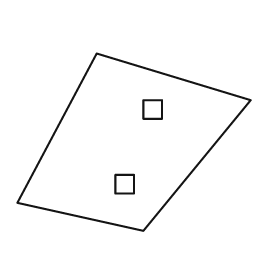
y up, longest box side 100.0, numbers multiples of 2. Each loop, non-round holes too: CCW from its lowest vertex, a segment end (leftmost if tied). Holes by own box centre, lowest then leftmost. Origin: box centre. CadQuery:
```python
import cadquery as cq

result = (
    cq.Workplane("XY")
    .moveTo(4.0, -38.0)
    .lineTo(50.0, 18.0)
    .lineTo(-16.0, 38.0)
    .lineTo(-50.0, -26.0)
    .close()
    .moveTo(-8.0, -22.0)
    .lineTo(0.0, -22.0)
    .lineTo(0.0, -14.0)
    .lineTo(-8.0, -14.0)
    .close()
    .moveTo(4.0, 10.0)
    .lineTo(12.0, 10.0)
    .lineTo(12.0, 18.0)
    .lineTo(4.0, 18.0)
    .close()
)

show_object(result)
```